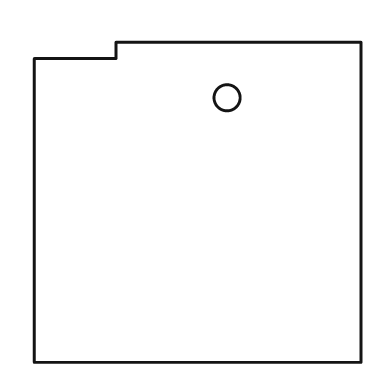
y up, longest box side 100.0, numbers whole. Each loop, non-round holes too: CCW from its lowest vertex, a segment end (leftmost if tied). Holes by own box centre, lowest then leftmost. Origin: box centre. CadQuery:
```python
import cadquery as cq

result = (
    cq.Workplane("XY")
    .moveTo(-50.0, -49.0)
    .lineTo(50.0, -49.0)
    .lineTo(50.0, 49.0)
    .lineTo(-25.0, 49.0)
    .lineTo(-25.0, 44.0)
    .lineTo(-50.0, 44.0)
    .close()
    .moveTo(9.0, 32.0)
    .circle(4.0)
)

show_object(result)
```